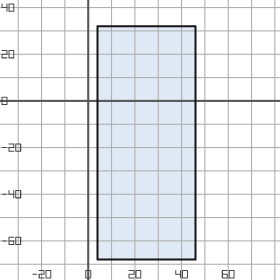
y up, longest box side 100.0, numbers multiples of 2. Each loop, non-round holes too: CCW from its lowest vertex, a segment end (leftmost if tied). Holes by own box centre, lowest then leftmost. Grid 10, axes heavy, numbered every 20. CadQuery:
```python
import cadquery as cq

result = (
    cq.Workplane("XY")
    .moveTo(4.0, -68.0)
    .lineTo(46.0, -68.0)
    .lineTo(46.0, 32.0)
    .lineTo(4.0, 32.0)
    .close()
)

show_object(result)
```